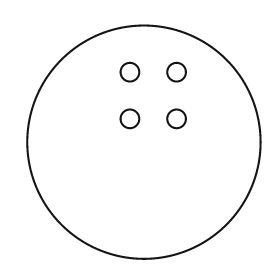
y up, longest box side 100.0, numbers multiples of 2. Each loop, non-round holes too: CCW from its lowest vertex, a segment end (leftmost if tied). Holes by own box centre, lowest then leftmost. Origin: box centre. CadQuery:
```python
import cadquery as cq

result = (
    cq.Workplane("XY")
    .moveTo(0.0, 0.0)
    .circle(50.0)
    .moveTo(-6.0, 10.0)
    .circle(4.0)
    .moveTo(14.0, 10.0)
    .circle(4.0)
    .moveTo(-6.0, 30.0)
    .circle(4.0)
    .moveTo(14.0, 30.0)
    .circle(4.0)
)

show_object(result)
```